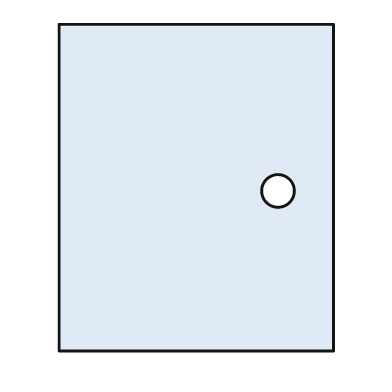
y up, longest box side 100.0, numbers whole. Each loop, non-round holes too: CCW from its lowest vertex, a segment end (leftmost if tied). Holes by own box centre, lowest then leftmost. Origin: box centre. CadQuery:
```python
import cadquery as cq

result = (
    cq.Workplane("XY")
    .moveTo(-42.0, -50.0)
    .lineTo(42.0, -50.0)
    .lineTo(42.0, 50.0)
    .lineTo(-42.0, 50.0)
    .close()
    .moveTo(25.0, -1.0)
    .circle(5.0)
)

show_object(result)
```